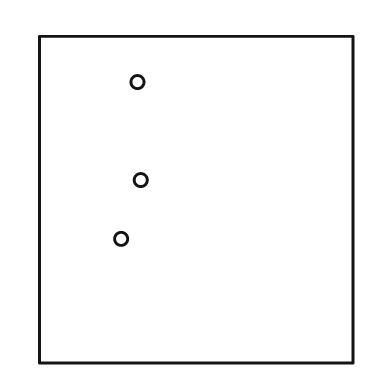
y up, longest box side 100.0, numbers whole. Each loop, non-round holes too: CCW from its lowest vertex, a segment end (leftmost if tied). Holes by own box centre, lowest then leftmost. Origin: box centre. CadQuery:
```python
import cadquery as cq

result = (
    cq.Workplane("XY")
    .moveTo(-48.0, -50.0)
    .lineTo(48.0, -50.0)
    .lineTo(48.0, 50.0)
    .lineTo(-48.0, 50.0)
    .close()
    .moveTo(-23.0, -12.0)
    .circle(2.0)
    .moveTo(-17.0, 6.0)
    .circle(2.0)
    .moveTo(-18.0, 36.0)
    .circle(2.0)
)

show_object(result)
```